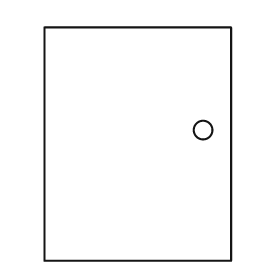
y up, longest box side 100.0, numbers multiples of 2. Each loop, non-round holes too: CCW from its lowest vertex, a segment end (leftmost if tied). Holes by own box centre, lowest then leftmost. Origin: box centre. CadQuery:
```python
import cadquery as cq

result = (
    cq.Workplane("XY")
    .moveTo(-40.0, -50.0)
    .lineTo(40.0, -50.0)
    .lineTo(40.0, 50.0)
    .lineTo(-40.0, 50.0)
    .close()
    .moveTo(28.0, 6.0)
    .circle(4.0)
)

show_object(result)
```